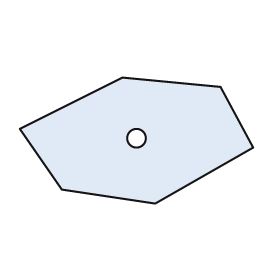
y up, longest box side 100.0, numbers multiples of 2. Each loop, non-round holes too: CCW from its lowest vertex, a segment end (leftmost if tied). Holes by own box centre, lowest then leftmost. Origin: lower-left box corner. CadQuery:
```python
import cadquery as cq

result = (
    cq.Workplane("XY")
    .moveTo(58.0, 0.0)
    .lineTo(100.0, 24.0)
    .lineTo(86.0, 50.0)
    .lineTo(44.0, 54.0)
    .lineTo(0.0, 32.0)
    .lineTo(18.0, 6.0)
    .close()
    .moveTo(50.0, 28.0)
    .circle(4.0)
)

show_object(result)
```